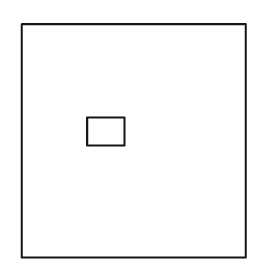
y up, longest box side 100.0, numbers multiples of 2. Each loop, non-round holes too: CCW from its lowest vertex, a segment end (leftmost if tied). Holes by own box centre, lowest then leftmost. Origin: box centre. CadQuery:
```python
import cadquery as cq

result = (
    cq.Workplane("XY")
    .moveTo(-48.0, -50.0)
    .lineTo(48.0, -50.0)
    .lineTo(48.0, 50.0)
    .lineTo(-48.0, 50.0)
    .close()
    .moveTo(-20.0, -2.0)
    .lineTo(-4.0, -2.0)
    .lineTo(-4.0, 10.0)
    .lineTo(-20.0, 10.0)
    .close()
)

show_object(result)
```